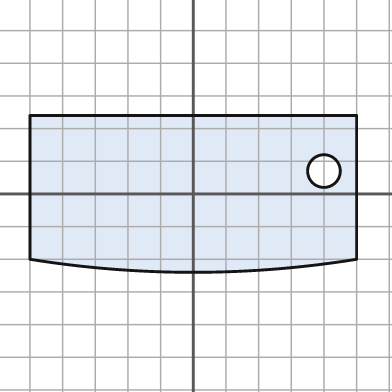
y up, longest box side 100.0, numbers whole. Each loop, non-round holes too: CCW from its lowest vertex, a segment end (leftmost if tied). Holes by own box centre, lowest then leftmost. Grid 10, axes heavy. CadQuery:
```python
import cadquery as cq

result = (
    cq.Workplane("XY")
    .moveTo(-50.0, -20.0)
    .threePointArc((0.0, -24.0), (50.0, -20.0))
    .lineTo(50.0, 24.0)
    .lineTo(-50.0, 24.0)
    .close()
    .moveTo(40.0, 7.0)
    .circle(5.0)
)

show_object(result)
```